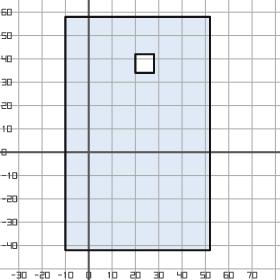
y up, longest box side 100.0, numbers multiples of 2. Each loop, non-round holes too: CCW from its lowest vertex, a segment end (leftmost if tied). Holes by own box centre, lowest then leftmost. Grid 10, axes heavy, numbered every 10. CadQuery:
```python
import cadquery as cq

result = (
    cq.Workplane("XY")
    .moveTo(-10.0, -42.0)
    .lineTo(52.0, -42.0)
    .lineTo(52.0, 58.0)
    .lineTo(-10.0, 58.0)
    .close()
    .moveTo(20.0, 34.0)
    .lineTo(28.0, 34.0)
    .lineTo(28.0, 42.0)
    .lineTo(20.0, 42.0)
    .close()
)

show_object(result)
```